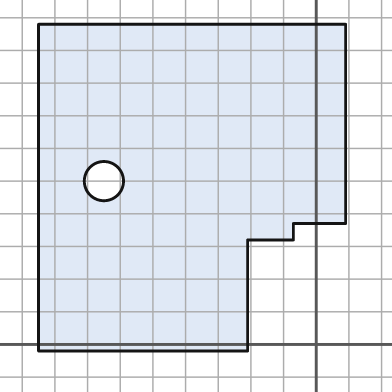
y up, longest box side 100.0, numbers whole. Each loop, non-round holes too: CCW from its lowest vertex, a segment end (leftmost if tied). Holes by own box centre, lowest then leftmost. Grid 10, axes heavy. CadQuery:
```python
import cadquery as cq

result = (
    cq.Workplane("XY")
    .moveTo(-85.0, -2.0)
    .lineTo(-21.0, -2.0)
    .lineTo(-21.0, 32.0)
    .lineTo(-7.0, 32.0)
    .lineTo(-7.0, 37.0)
    .lineTo(9.0, 37.0)
    .lineTo(9.0, 98.0)
    .lineTo(-85.0, 98.0)
    .close()
    .moveTo(-65.0, 50.0)
    .circle(6.0)
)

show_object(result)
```